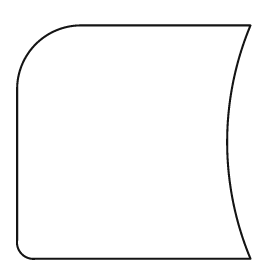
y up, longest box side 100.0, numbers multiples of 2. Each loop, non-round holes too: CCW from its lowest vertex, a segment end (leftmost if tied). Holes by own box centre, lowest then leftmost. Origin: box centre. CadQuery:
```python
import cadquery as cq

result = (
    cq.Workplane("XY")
    .moveTo(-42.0, -50.0)
    .lineTo(50.0, -50.0)
    .threePointArc((40.0, 0.0), (50.0, 50.0))
    .lineTo(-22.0, 50.0)
    .threePointArc((-42.0, 42.0), (-50.0, 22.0))
    .lineTo(-50.0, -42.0)
    .threePointArc((-48.0, -48.0), (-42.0, -50.0))
    .close()
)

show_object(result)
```